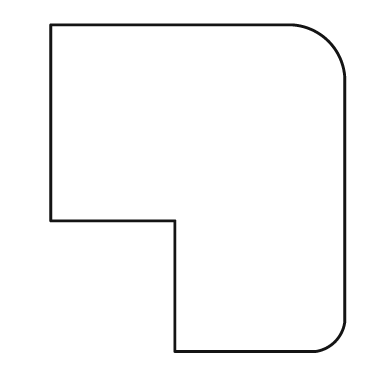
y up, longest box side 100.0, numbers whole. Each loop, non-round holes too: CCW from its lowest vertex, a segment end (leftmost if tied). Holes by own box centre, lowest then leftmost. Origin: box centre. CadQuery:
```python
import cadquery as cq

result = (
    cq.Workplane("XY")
    .moveTo(-7.0, -50.0)
    .lineTo(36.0, -50.0)
    .threePointArc((42.0, -47.0), (45.0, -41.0))
    .lineTo(45.0, 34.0)
    .threePointArc((40.0, 45.0), (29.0, 50.0))
    .lineTo(-45.0, 50.0)
    .lineTo(-45.0, -10.0)
    .lineTo(-7.0, -10.0)
    .close()
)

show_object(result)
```